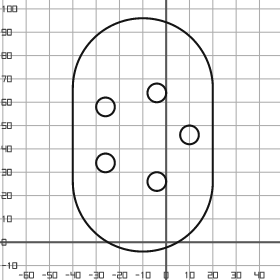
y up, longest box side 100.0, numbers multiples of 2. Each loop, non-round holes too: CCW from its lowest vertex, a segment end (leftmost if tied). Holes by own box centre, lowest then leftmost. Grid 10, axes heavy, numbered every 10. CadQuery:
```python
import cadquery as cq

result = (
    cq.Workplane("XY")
    .moveTo(-40.0, 26.0)
    .threePointArc((-10.0, -4.0), (20.0, 26.0))
    .lineTo(20.0, 66.0)
    .threePointArc((-10.0, 96.0), (-40.0, 66.0))
    .close()
    .moveTo(-4.0, 26.0)
    .circle(4.0)
    .moveTo(-26.0, 34.0)
    .circle(4.0)
    .moveTo(10.0, 46.0)
    .circle(4.0)
    .moveTo(-26.0, 58.0)
    .circle(4.0)
    .moveTo(-4.0, 64.0)
    .circle(4.0)
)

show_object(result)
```